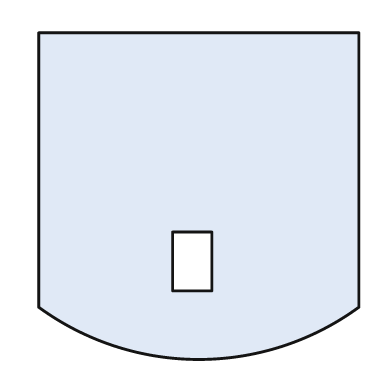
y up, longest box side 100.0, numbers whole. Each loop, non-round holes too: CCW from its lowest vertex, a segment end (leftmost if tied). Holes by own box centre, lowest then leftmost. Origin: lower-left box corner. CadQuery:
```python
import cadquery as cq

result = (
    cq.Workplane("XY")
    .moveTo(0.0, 16.0)
    .threePointArc((49.0, 0.0), (98.0, 16.0))
    .lineTo(98.0, 100.0)
    .lineTo(0.0, 100.0)
    .close()
    .moveTo(41.0, 21.0)
    .lineTo(53.0, 21.0)
    .lineTo(53.0, 39.0)
    .lineTo(41.0, 39.0)
    .close()
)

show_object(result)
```